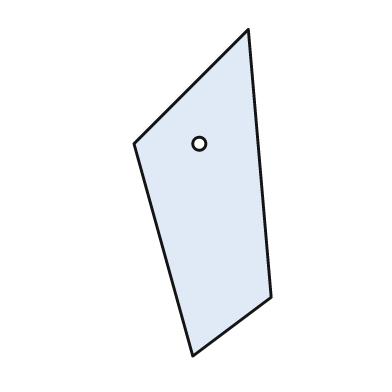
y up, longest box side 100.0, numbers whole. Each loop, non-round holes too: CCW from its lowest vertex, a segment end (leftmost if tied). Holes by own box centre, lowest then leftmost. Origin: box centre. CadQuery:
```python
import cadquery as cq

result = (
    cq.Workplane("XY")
    .moveTo(-3.0, -50.0)
    .lineTo(21.0, -32.0)
    .lineTo(14.0, 50.0)
    .lineTo(-21.0, 15.0)
    .close()
    .moveTo(-1.0, 15.0)
    .circle(2.0)
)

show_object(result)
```